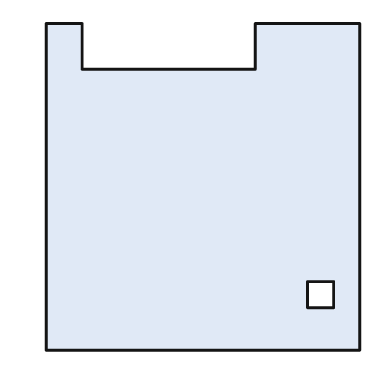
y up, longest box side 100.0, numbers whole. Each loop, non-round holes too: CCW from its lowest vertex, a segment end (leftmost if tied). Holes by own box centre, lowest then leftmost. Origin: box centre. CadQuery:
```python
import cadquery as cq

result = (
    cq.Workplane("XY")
    .moveTo(-48.0, -50.0)
    .lineTo(48.0, -50.0)
    .lineTo(48.0, 50.0)
    .lineTo(16.0, 50.0)
    .lineTo(16.0, 36.0)
    .lineTo(-37.0, 36.0)
    .lineTo(-37.0, 50.0)
    .lineTo(-48.0, 50.0)
    .close()
    .moveTo(32.0, -37.0)
    .lineTo(40.0, -37.0)
    .lineTo(40.0, -29.0)
    .lineTo(32.0, -29.0)
    .close()
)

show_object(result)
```